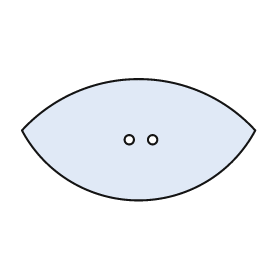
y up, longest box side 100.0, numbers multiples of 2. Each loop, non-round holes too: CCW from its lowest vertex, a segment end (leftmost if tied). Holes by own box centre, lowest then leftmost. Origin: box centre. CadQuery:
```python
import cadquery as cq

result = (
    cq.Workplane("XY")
    .moveTo(-50.0, 4.0)
    .threePointArc((0.0, -26.0), (50.0, 4.0))
    .threePointArc((0.0, 26.0), (-50.0, 4.0))
    .close()
    .moveTo(-4.0, 0.0)
    .circle(2.0)
    .moveTo(6.0, 0.0)
    .circle(2.0)
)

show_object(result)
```